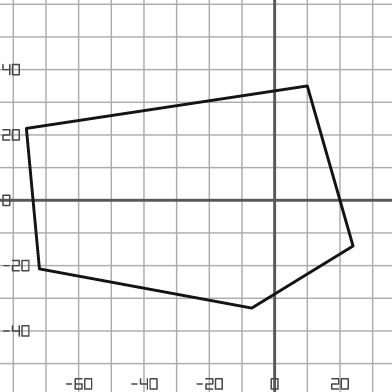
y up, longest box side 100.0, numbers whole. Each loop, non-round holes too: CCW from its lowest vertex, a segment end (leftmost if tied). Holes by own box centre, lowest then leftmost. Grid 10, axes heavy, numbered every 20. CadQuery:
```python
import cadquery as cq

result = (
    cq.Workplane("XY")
    .moveTo(-7.0, -33.0)
    .lineTo(24.0, -14.0)
    .lineTo(10.0, 35.0)
    .lineTo(-76.0, 22.0)
    .lineTo(-72.0, -21.0)
    .close()
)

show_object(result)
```